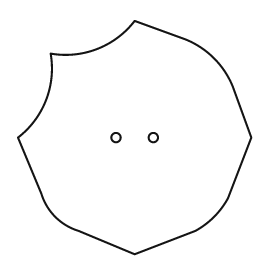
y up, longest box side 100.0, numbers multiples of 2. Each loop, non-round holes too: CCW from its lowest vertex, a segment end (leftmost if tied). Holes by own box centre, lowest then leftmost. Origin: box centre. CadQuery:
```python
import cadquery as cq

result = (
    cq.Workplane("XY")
    .moveTo(0.0, -50.0)
    .lineTo(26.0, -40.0)
    .threePointArc((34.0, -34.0), (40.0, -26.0))
    .lineTo(50.0, 0.0)
    .lineTo(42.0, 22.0)
    .threePointArc((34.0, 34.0), (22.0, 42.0))
    .lineTo(0.0, 50.0)
    .threePointArc((-16.0, 38.0), (-36.0, 36.0))
    .threePointArc((-38.0, 16.0), (-50.0, 0.0))
    .lineTo(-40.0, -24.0)
    .threePointArc((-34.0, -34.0), (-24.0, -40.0))
    .close()
    .moveTo(-8.0, 0.0)
    .circle(2.0)
    .moveTo(8.0, 0.0)
    .circle(2.0)
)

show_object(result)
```